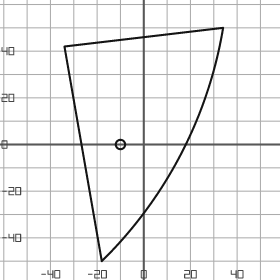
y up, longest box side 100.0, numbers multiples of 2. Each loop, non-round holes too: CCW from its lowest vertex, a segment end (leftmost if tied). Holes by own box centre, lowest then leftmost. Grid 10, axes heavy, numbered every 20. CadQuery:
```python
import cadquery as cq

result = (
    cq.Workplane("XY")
    .moveTo(-18.0, -50.0)
    .threePointArc((16.0, -4.0), (34.0, 50.0))
    .lineTo(-34.0, 42.0)
    .close()
    .moveTo(-10.0, 0.0)
    .circle(2.0)
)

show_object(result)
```